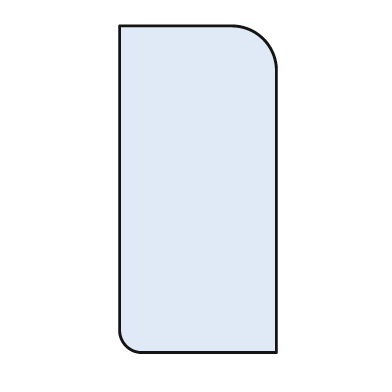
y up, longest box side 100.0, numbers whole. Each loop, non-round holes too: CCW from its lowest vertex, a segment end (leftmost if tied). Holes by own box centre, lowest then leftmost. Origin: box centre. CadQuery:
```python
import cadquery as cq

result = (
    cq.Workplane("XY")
    .moveTo(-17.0, -50.0)
    .lineTo(24.0, -50.0)
    .lineTo(24.0, 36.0)
    .threePointArc((20.0, 46.0), (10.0, 50.0))
    .lineTo(-24.0, 50.0)
    .lineTo(-24.0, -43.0)
    .threePointArc((-22.0, -48.0), (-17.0, -50.0))
    .close()
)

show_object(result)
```